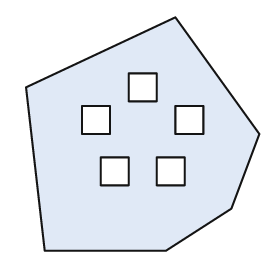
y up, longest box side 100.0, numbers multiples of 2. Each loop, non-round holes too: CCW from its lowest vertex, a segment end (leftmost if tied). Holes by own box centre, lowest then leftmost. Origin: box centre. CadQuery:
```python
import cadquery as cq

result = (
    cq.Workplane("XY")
    .moveTo(-42.0, -50.0)
    .lineTo(10.0, -50.0)
    .lineTo(38.0, -32.0)
    .lineTo(50.0, 0.0)
    .lineTo(14.0, 50.0)
    .lineTo(-50.0, 20.0)
    .close()
    .moveTo(-18.0, -22.0)
    .lineTo(-6.0, -22.0)
    .lineTo(-6.0, -10.0)
    .lineTo(-18.0, -10.0)
    .close()
    .moveTo(6.0, -22.0)
    .lineTo(18.0, -22.0)
    .lineTo(18.0, -10.0)
    .lineTo(6.0, -10.0)
    .close()
    .moveTo(-26.0, 0.0)
    .lineTo(-14.0, 0.0)
    .lineTo(-14.0, 12.0)
    .lineTo(-26.0, 12.0)
    .close()
    .moveTo(14.0, 0.0)
    .lineTo(26.0, 0.0)
    .lineTo(26.0, 12.0)
    .lineTo(14.0, 12.0)
    .close()
    .moveTo(-6.0, 14.0)
    .lineTo(6.0, 14.0)
    .lineTo(6.0, 26.0)
    .lineTo(-6.0, 26.0)
    .close()
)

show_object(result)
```